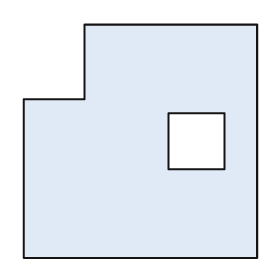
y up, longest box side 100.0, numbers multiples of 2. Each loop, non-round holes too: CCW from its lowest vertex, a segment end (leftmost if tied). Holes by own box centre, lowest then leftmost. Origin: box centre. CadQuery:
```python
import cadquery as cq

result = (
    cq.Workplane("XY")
    .moveTo(-50.0, -50.0)
    .lineTo(50.0, -50.0)
    .lineTo(50.0, 50.0)
    .lineTo(-24.0, 50.0)
    .lineTo(-24.0, 18.0)
    .lineTo(-50.0, 18.0)
    .close()
    .moveTo(12.0, -12.0)
    .lineTo(36.0, -12.0)
    .lineTo(36.0, 12.0)
    .lineTo(12.0, 12.0)
    .close()
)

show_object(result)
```